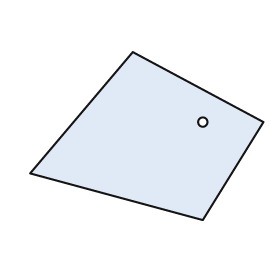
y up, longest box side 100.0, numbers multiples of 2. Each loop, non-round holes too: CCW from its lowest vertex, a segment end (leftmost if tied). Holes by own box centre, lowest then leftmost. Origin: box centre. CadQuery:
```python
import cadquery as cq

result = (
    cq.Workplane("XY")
    .moveTo(24.0, -36.0)
    .lineTo(50.0, 6.0)
    .lineTo(-6.0, 36.0)
    .lineTo(-50.0, -16.0)
    .close()
    .moveTo(24.0, 6.0)
    .circle(2.0)
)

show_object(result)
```